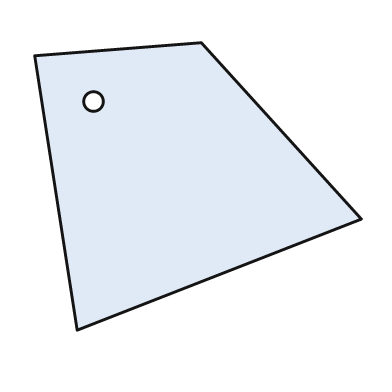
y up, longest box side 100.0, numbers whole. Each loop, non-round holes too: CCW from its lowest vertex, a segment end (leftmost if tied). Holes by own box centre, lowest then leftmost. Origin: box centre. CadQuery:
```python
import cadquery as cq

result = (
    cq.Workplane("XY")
    .moveTo(-37.0, -44.0)
    .lineTo(50.0, -10.0)
    .lineTo(1.0, 44.0)
    .lineTo(-50.0, 40.0)
    .close()
    .moveTo(-32.0, 26.0)
    .circle(3.0)
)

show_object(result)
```